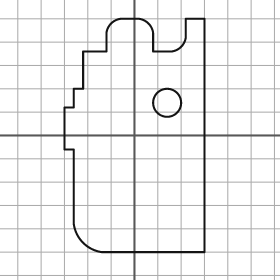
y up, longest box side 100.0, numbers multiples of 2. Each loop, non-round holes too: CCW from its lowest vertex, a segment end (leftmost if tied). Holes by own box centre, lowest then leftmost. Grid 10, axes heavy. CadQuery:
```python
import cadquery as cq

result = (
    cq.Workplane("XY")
    .moveTo(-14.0, -50.0)
    .lineTo(30.0, -50.0)
    .lineTo(30.0, 50.0)
    .lineTo(22.0, 50.0)
    .lineTo(22.0, 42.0)
    .threePointArc((20.0, 38.0), (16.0, 36.0))
    .lineTo(8.0, 36.0)
    .lineTo(8.0, 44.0)
    .threePointArc((6.0, 48.0), (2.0, 50.0))
    .lineTo(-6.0, 50.0)
    .threePointArc((-10.0, 48.0), (-12.0, 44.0))
    .lineTo(-12.0, 36.0)
    .lineTo(-22.0, 36.0)
    .lineTo(-22.0, 20.0)
    .lineTo(-26.0, 20.0)
    .lineTo(-26.0, 12.0)
    .lineTo(-30.0, 12.0)
    .lineTo(-30.0, -6.0)
    .lineTo(-26.0, -6.0)
    .lineTo(-26.0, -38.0)
    .threePointArc((-22.0, -46.0), (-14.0, -50.0))
    .close()
    .moveTo(14.0, 14.0)
    .circle(6.0)
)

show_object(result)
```